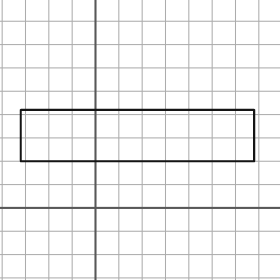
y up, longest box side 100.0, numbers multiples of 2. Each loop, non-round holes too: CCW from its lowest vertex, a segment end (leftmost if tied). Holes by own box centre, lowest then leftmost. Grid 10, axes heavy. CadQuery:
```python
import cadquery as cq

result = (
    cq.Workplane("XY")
    .moveTo(-32.0, 20.0)
    .lineTo(68.0, 20.0)
    .lineTo(68.0, 42.0)
    .lineTo(-32.0, 42.0)
    .close()
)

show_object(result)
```